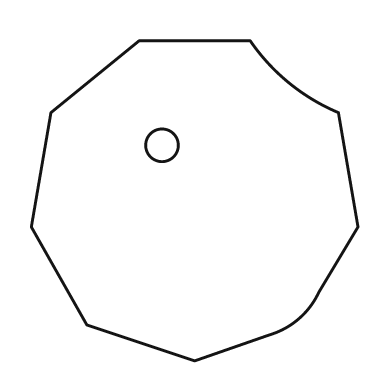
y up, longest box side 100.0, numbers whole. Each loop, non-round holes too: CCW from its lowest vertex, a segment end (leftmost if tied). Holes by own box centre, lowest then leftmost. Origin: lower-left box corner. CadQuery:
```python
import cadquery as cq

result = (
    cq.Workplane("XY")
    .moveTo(50.0, 0.0)
    .lineTo(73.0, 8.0)
    .threePointArc((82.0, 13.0), (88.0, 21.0))
    .lineTo(100.0, 41.0)
    .lineTo(94.0, 76.0)
    .threePointArc((79.0, 85.0), (67.0, 98.0))
    .lineTo(33.0, 98.0)
    .lineTo(6.0, 76.0)
    .lineTo(0.0, 41.0)
    .lineTo(17.0, 11.0)
    .close()
    .moveTo(40.0, 66.0)
    .circle(5.0)
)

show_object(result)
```